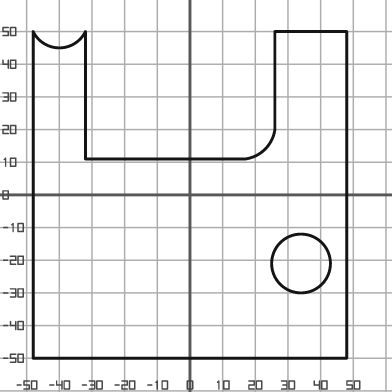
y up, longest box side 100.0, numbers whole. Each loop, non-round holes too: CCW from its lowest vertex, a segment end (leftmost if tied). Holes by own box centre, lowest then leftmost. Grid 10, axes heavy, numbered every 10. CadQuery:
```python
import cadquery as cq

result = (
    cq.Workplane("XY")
    .moveTo(-48.0, -50.0)
    .lineTo(48.0, -50.0)
    .lineTo(48.0, 50.0)
    .lineTo(26.0, 50.0)
    .lineTo(26.0, 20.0)
    .threePointArc((23.0, 14.0), (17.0, 11.0))
    .lineTo(-32.0, 11.0)
    .lineTo(-32.0, 50.0)
    .threePointArc((-40.0, 45.0), (-48.0, 50.0))
    .close()
    .moveTo(34.0, -21.0)
    .circle(9.0)
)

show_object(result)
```